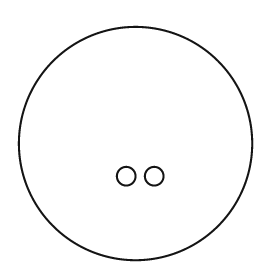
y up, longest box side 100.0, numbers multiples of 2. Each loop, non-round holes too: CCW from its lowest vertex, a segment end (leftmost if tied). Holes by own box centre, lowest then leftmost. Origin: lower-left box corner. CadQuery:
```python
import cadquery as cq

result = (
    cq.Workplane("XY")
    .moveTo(50.0, 50.0)
    .circle(50.0)
    .moveTo(46.0, 36.0)
    .circle(4.0)
    .moveTo(58.0, 36.0)
    .circle(4.0)
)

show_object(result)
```